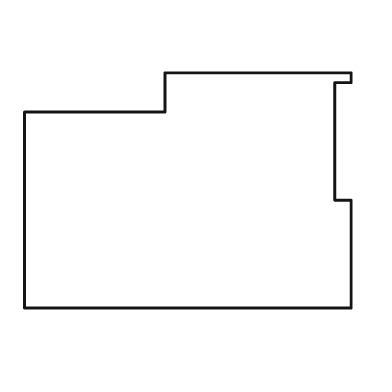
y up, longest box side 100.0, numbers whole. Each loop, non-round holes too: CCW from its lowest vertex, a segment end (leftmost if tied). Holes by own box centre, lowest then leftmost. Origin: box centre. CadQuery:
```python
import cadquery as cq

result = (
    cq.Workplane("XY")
    .moveTo(-50.0, -36.0)
    .lineTo(50.0, -36.0)
    .lineTo(50.0, -3.0)
    .lineTo(45.0, -3.0)
    .lineTo(45.0, 33.0)
    .lineTo(50.0, 33.0)
    .lineTo(50.0, 36.0)
    .lineTo(-7.0, 36.0)
    .lineTo(-7.0, 24.0)
    .lineTo(-50.0, 24.0)
    .close()
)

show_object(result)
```